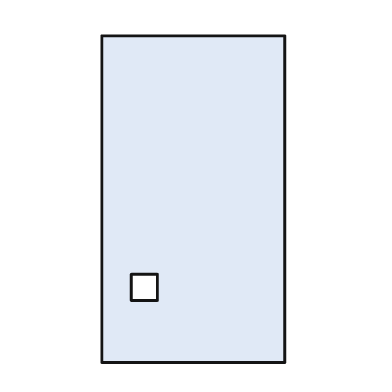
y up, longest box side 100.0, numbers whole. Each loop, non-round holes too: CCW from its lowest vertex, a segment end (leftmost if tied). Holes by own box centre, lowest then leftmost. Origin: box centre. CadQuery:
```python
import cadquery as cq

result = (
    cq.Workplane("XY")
    .moveTo(-28.0, -50.0)
    .lineTo(28.0, -50.0)
    .lineTo(28.0, 50.0)
    .lineTo(-28.0, 50.0)
    .close()
    .moveTo(-19.0, -31.0)
    .lineTo(-11.0, -31.0)
    .lineTo(-11.0, -23.0)
    .lineTo(-19.0, -23.0)
    .close()
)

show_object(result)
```